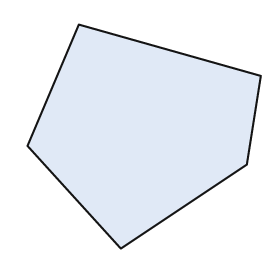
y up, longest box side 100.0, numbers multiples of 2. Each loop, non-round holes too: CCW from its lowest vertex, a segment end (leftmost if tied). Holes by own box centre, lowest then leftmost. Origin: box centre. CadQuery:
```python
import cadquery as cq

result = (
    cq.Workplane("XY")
    .moveTo(-10.0, -48.0)
    .lineTo(44.0, -12.0)
    .lineTo(50.0, 26.0)
    .lineTo(-28.0, 48.0)
    .lineTo(-50.0, -4.0)
    .close()
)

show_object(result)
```